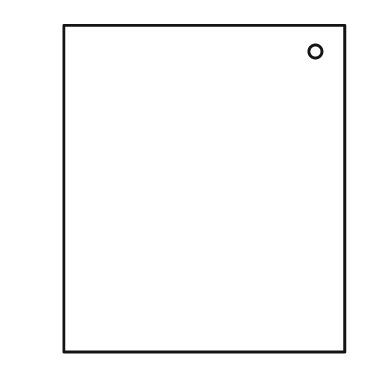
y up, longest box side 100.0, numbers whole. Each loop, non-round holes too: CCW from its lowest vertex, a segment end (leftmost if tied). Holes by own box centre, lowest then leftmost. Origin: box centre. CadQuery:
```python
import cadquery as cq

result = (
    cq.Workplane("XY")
    .moveTo(-43.0, -50.0)
    .lineTo(43.0, -50.0)
    .lineTo(43.0, 50.0)
    .lineTo(-43.0, 50.0)
    .close()
    .moveTo(34.0, 42.0)
    .circle(2.0)
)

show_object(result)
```